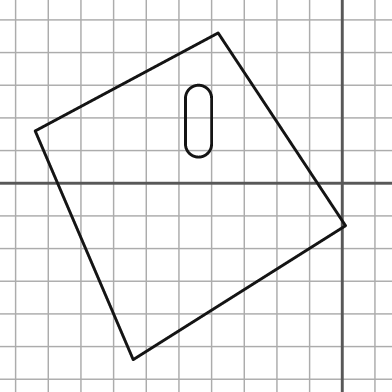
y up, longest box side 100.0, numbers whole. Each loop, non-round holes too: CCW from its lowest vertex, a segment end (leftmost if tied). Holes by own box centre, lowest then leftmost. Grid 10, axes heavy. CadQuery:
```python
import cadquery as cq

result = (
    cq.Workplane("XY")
    .moveTo(-64.0, -54.0)
    .lineTo(1.0, -13.0)
    .lineTo(-38.0, 46.0)
    .lineTo(-94.0, 16.0)
    .close()
    .moveTo(-48.0, 12.0)
    .threePointArc((-44.0, 8.0), (-40.0, 12.0))
    .lineTo(-40.0, 26.0)
    .threePointArc((-44.0, 30.0), (-48.0, 26.0))
    .close()
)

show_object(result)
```